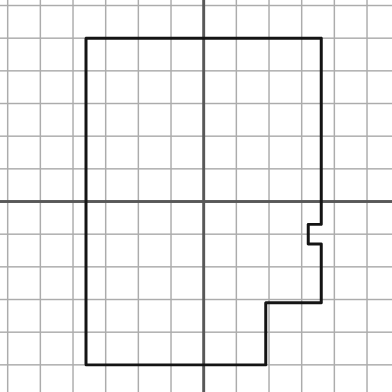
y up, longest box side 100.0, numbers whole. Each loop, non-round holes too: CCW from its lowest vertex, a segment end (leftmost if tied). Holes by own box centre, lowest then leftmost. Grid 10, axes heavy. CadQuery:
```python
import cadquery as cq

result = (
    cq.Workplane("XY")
    .moveTo(-36.0, -50.0)
    .lineTo(19.0, -50.0)
    .lineTo(19.0, -31.0)
    .lineTo(36.0, -31.0)
    .lineTo(36.0, -13.0)
    .lineTo(32.0, -13.0)
    .lineTo(32.0, -7.0)
    .lineTo(36.0, -7.0)
    .lineTo(36.0, 50.0)
    .lineTo(-36.0, 50.0)
    .close()
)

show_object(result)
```